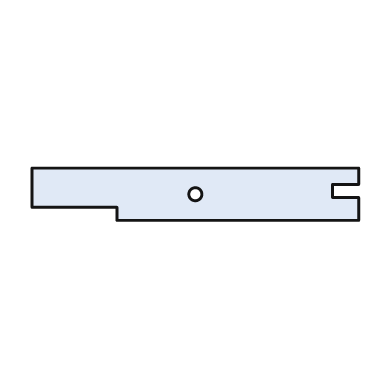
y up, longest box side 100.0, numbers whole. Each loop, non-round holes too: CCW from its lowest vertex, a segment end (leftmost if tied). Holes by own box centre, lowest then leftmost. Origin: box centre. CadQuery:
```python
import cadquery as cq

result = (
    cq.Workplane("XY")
    .moveTo(-24.0, -8.0)
    .lineTo(50.0, -8.0)
    .lineTo(50.0, -1.0)
    .lineTo(42.0, -1.0)
    .lineTo(42.0, 3.0)
    .lineTo(50.0, 3.0)
    .lineTo(50.0, 8.0)
    .lineTo(-50.0, 8.0)
    .lineTo(-50.0, -4.0)
    .lineTo(-24.0, -4.0)
    .close()
    .moveTo(0.0, 0.0)
    .circle(2.0)
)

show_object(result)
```